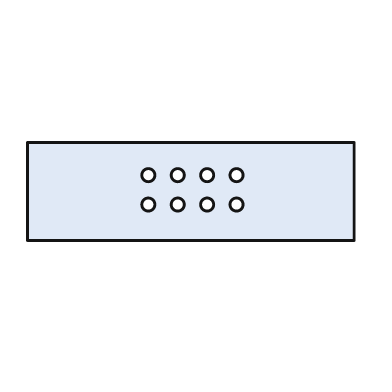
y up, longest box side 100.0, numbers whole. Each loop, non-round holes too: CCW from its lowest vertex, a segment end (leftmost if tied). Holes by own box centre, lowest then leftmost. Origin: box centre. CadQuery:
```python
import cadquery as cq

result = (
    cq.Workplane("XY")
    .moveTo(-50.0, -15.0)
    .lineTo(50.0, -15.0)
    .lineTo(50.0, 15.0)
    .lineTo(-50.0, 15.0)
    .close()
    .moveTo(-13.0, -4.0)
    .circle(2.0)
    .moveTo(-4.0, -4.0)
    .circle(2.0)
    .moveTo(5.0, -4.0)
    .circle(2.0)
    .moveTo(14.0, -4.0)
    .circle(2.0)
    .moveTo(-13.0, 5.0)
    .circle(2.0)
    .moveTo(-4.0, 5.0)
    .circle(2.0)
    .moveTo(5.0, 5.0)
    .circle(2.0)
    .moveTo(14.0, 5.0)
    .circle(2.0)
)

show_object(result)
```